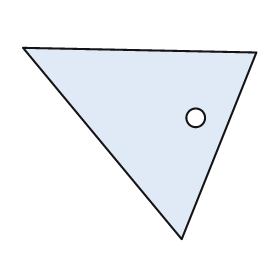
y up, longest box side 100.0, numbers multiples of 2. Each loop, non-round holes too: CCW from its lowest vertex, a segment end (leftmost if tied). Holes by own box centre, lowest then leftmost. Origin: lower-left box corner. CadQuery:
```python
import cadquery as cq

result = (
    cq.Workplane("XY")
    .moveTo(68.0, 0.0)
    .lineTo(100.0, 80.0)
    .lineTo(0.0, 82.0)
    .close()
    .moveTo(74.0, 52.0)
    .circle(4.0)
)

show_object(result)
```